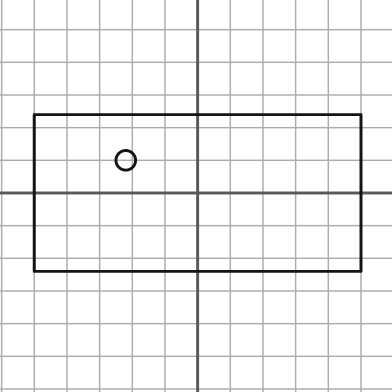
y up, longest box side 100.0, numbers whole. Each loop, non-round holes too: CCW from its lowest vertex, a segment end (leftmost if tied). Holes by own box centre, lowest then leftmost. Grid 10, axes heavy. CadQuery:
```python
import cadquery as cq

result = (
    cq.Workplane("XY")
    .moveTo(-50.0, -24.0)
    .lineTo(50.0, -24.0)
    .lineTo(50.0, 24.0)
    .lineTo(-50.0, 24.0)
    .close()
    .moveTo(-22.0, 10.0)
    .circle(3.0)
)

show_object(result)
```